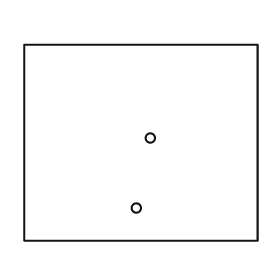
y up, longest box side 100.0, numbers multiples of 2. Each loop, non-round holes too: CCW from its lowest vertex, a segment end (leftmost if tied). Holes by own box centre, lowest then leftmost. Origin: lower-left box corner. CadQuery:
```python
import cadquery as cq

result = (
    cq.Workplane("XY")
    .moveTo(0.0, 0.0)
    .lineTo(100.0, 0.0)
    .lineTo(100.0, 84.0)
    .lineTo(0.0, 84.0)
    .close()
    .moveTo(48.0, 14.0)
    .circle(2.0)
    .moveTo(54.0, 44.0)
    .circle(2.0)
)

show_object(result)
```